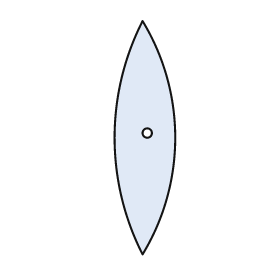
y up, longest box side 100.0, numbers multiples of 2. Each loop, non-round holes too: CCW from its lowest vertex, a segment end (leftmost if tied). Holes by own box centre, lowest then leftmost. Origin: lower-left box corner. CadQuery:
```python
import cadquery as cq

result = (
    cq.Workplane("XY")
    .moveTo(12.0, 0.0)
    .threePointArc((26.0, 50.0), (12.0, 100.0))
    .threePointArc((0.0, 50.0), (12.0, 0.0))
    .close()
    .moveTo(14.0, 52.0)
    .circle(2.0)
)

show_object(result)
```